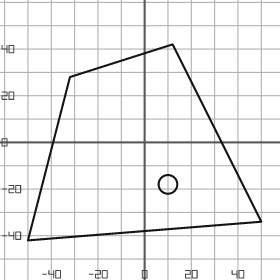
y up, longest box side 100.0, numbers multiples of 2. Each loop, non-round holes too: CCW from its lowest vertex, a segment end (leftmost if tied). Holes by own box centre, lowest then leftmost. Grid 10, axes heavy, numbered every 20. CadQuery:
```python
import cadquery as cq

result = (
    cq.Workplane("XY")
    .moveTo(-50.0, -42.0)
    .lineTo(50.0, -34.0)
    .lineTo(12.0, 42.0)
    .lineTo(-32.0, 28.0)
    .close()
    .moveTo(10.0, -18.0)
    .circle(4.0)
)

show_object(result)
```